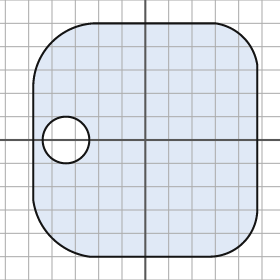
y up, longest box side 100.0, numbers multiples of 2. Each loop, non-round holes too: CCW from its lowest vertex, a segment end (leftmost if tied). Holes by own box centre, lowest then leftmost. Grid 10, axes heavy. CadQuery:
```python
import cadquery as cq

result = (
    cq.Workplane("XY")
    .moveTo(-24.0, -50.0)
    .lineTo(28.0, -50.0)
    .threePointArc((42.0, -44.0), (48.0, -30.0))
    .lineTo(48.0, 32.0)
    .threePointArc((42.0, 44.0), (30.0, 50.0))
    .lineTo(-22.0, 50.0)
    .threePointArc((-40.0, 42.0), (-48.0, 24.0))
    .lineTo(-48.0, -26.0)
    .threePointArc((-40.0, -42.0), (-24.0, -50.0))
    .close()
    .moveTo(-34.0, 0.0)
    .circle(10.0)
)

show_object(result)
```